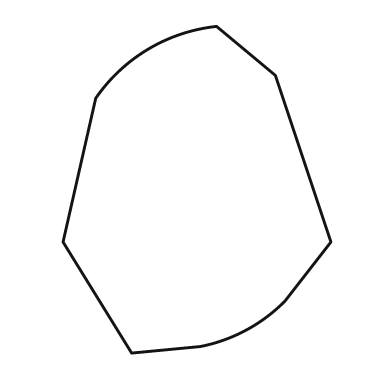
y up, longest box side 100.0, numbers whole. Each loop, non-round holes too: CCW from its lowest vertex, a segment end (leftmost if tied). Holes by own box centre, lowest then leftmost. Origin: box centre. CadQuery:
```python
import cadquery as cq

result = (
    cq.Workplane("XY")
    .moveTo(-20.0, -50.0)
    .lineTo(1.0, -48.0)
    .threePointArc((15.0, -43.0), (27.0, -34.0))
    .lineTo(41.0, -16.0)
    .lineTo(24.0, 35.0)
    .lineTo(6.0, 50.0)
    .threePointArc((-15.0, 43.0), (-31.0, 28.0))
    .lineTo(-41.0, -16.0)
    .close()
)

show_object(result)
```